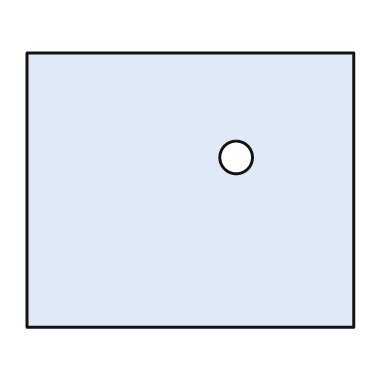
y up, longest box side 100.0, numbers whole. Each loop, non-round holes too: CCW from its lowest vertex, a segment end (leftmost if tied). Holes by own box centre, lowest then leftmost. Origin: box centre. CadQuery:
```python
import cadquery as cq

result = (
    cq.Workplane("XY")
    .moveTo(-50.0, -42.0)
    .lineTo(50.0, -42.0)
    .lineTo(50.0, 42.0)
    .lineTo(-50.0, 42.0)
    .close()
    .moveTo(14.0, 10.0)
    .circle(5.0)
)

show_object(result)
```